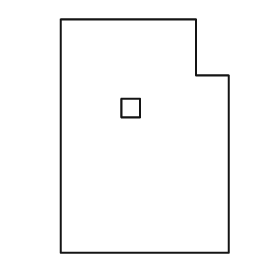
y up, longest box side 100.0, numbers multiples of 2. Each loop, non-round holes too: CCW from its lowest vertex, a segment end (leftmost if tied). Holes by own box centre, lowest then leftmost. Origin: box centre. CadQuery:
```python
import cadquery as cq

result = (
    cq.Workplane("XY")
    .moveTo(-36.0, -50.0)
    .lineTo(36.0, -50.0)
    .lineTo(36.0, 26.0)
    .lineTo(22.0, 26.0)
    .lineTo(22.0, 50.0)
    .lineTo(-36.0, 50.0)
    .close()
    .moveTo(-10.0, 8.0)
    .lineTo(-2.0, 8.0)
    .lineTo(-2.0, 16.0)
    .lineTo(-10.0, 16.0)
    .close()
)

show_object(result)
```